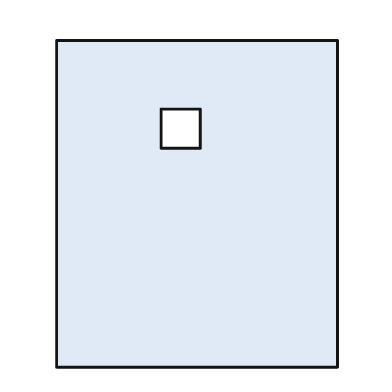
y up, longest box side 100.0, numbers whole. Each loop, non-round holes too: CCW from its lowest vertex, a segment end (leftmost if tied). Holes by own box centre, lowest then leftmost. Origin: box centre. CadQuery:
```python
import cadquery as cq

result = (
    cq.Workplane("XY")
    .moveTo(-43.0, -50.0)
    .lineTo(43.0, -50.0)
    .lineTo(43.0, 50.0)
    .lineTo(-43.0, 50.0)
    .close()
    .moveTo(-11.0, 17.0)
    .lineTo(1.0, 17.0)
    .lineTo(1.0, 29.0)
    .lineTo(-11.0, 29.0)
    .close()
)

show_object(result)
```